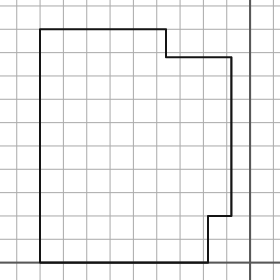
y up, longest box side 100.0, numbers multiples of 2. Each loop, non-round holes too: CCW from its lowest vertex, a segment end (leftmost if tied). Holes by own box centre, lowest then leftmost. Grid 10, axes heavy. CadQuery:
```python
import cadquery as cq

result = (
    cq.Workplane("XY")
    .moveTo(-90.0, 0.0)
    .lineTo(-18.0, 0.0)
    .lineTo(-18.0, 20.0)
    .lineTo(-8.0, 20.0)
    .lineTo(-8.0, 88.0)
    .lineTo(-36.0, 88.0)
    .lineTo(-36.0, 100.0)
    .lineTo(-90.0, 100.0)
    .close()
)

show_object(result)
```